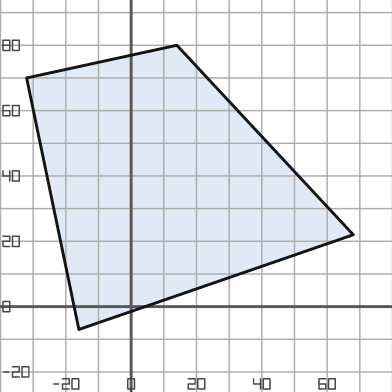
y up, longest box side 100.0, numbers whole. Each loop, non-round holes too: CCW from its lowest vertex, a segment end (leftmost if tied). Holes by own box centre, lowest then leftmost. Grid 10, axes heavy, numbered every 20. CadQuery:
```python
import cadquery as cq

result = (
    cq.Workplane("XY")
    .moveTo(-16.0, -7.0)
    .lineTo(68.0, 22.0)
    .lineTo(14.0, 80.0)
    .lineTo(-32.0, 70.0)
    .close()
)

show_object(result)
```